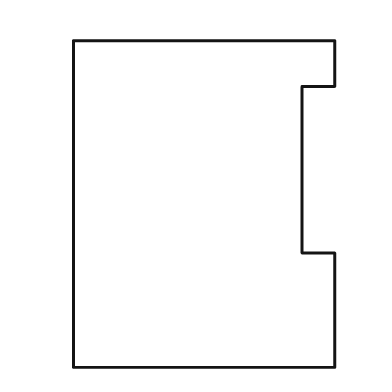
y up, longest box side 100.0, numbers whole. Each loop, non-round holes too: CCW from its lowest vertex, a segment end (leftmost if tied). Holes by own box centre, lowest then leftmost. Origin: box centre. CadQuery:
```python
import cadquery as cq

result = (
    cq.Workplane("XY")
    .moveTo(-40.0, -50.0)
    .lineTo(40.0, -50.0)
    .lineTo(40.0, -15.0)
    .lineTo(30.0, -15.0)
    .lineTo(30.0, 36.0)
    .lineTo(40.0, 36.0)
    .lineTo(40.0, 50.0)
    .lineTo(-40.0, 50.0)
    .close()
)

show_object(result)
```